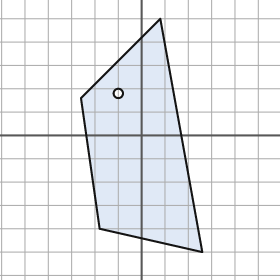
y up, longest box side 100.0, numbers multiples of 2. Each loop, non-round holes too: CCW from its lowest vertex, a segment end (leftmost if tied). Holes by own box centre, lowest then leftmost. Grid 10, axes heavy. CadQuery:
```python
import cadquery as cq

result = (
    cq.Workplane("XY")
    .moveTo(26.0, -50.0)
    .lineTo(8.0, 50.0)
    .lineTo(-26.0, 16.0)
    .lineTo(-18.0, -40.0)
    .close()
    .moveTo(-10.0, 18.0)
    .circle(2.0)
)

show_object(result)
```